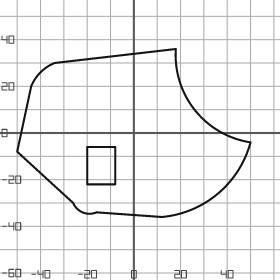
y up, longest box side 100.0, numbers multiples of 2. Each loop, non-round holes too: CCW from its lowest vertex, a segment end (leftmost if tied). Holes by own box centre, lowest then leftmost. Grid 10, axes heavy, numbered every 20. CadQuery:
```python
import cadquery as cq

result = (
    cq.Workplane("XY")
    .moveTo(12.0, -36.0)
    .threePointArc((36.0, -26.0), (50.0, -4.0))
    .threePointArc((26.0, 10.0), (18.0, 36.0))
    .lineTo(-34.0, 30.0)
    .threePointArc((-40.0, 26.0), (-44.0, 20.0))
    .lineTo(-50.0, -8.0)
    .lineTo(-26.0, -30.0)
    .threePointArc((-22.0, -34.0), (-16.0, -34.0))
    .close()
    .moveTo(-20.0, -22.0)
    .lineTo(-8.0, -22.0)
    .lineTo(-8.0, -6.0)
    .lineTo(-20.0, -6.0)
    .close()
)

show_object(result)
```